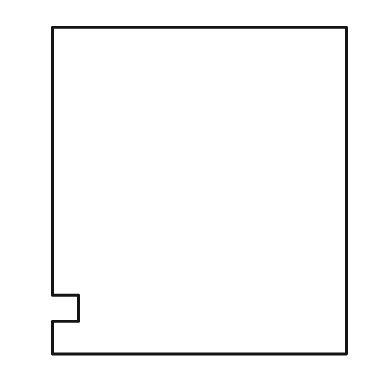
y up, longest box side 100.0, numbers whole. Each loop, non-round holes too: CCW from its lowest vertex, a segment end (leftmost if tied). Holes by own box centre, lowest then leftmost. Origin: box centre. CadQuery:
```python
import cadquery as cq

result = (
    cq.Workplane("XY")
    .moveTo(-45.0, -50.0)
    .lineTo(45.0, -50.0)
    .lineTo(45.0, 50.0)
    .lineTo(-45.0, 50.0)
    .lineTo(-45.0, -32.0)
    .lineTo(-37.0, -32.0)
    .lineTo(-37.0, -40.0)
    .lineTo(-45.0, -40.0)
    .close()
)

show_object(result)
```